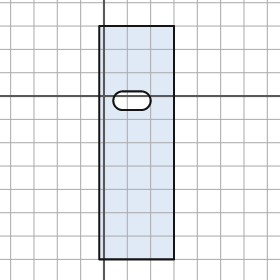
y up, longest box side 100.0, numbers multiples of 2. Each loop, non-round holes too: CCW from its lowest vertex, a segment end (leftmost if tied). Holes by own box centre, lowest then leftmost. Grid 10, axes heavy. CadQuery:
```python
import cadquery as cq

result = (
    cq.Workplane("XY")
    .moveTo(-2.0, -70.0)
    .lineTo(30.0, -70.0)
    .lineTo(30.0, 30.0)
    .lineTo(-2.0, 30.0)
    .close()
    .moveTo(8.0, -6.0)
    .lineTo(16.0, -6.0)
    .threePointArc((20.0, -2.0), (16.0, 2.0))
    .lineTo(8.0, 2.0)
    .threePointArc((4.0, -2.0), (8.0, -6.0))
    .close()
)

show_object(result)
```